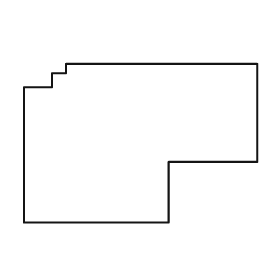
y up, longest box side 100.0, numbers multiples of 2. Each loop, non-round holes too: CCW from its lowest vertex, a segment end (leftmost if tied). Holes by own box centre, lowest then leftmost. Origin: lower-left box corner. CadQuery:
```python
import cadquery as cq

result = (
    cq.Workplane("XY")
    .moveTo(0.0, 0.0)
    .lineTo(62.0, 0.0)
    .lineTo(62.0, 26.0)
    .lineTo(100.0, 26.0)
    .lineTo(100.0, 68.0)
    .lineTo(18.0, 68.0)
    .lineTo(18.0, 64.0)
    .lineTo(12.0, 64.0)
    .lineTo(12.0, 58.0)
    .lineTo(0.0, 58.0)
    .close()
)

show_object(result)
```